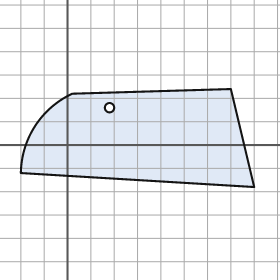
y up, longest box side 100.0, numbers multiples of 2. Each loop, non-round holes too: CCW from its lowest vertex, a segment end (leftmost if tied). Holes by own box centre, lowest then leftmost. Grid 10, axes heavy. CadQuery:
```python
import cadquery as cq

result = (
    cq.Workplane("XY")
    .moveTo(80.0, -18.0)
    .lineTo(70.0, 24.0)
    .lineTo(2.0, 22.0)
    .threePointArc((-14.0, 8.0), (-20.0, -12.0))
    .close()
    .moveTo(18.0, 16.0)
    .circle(2.0)
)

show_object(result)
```